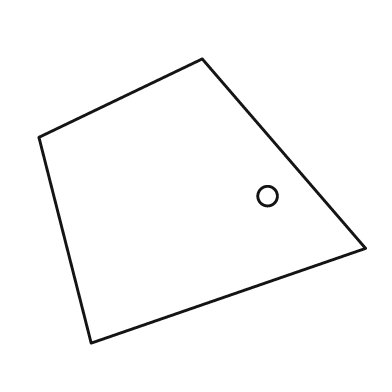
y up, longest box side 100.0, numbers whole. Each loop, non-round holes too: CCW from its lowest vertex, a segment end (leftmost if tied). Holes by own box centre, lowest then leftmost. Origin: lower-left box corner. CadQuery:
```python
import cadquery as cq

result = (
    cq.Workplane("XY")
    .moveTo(16.0, 0.0)
    .lineTo(100.0, 29.0)
    .lineTo(50.0, 87.0)
    .lineTo(0.0, 63.0)
    .close()
    .moveTo(70.0, 45.0)
    .circle(3.0)
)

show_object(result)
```